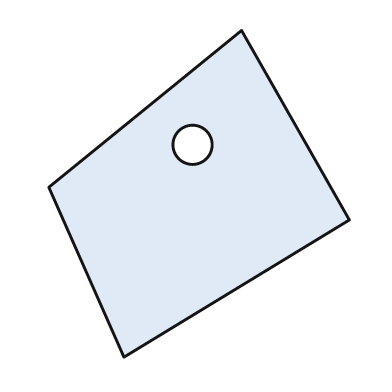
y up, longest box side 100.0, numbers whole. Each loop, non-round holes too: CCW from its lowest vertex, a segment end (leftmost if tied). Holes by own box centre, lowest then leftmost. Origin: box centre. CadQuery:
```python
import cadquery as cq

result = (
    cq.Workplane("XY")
    .moveTo(-23.0, -50.0)
    .lineTo(46.0, -8.0)
    .lineTo(13.0, 50.0)
    .lineTo(-46.0, 2.0)
    .close()
    .moveTo(-2.0, 15.0)
    .circle(6.0)
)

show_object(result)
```